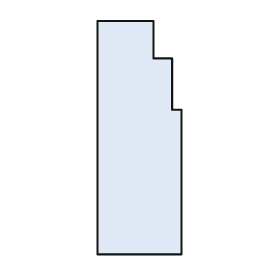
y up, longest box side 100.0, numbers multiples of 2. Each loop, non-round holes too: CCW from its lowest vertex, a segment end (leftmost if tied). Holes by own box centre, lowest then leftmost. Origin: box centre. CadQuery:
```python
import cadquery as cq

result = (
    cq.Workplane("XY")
    .moveTo(-18.0, -50.0)
    .lineTo(18.0, -50.0)
    .lineTo(18.0, 12.0)
    .lineTo(14.0, 12.0)
    .lineTo(14.0, 34.0)
    .lineTo(6.0, 34.0)
    .lineTo(6.0, 50.0)
    .lineTo(-18.0, 50.0)
    .close()
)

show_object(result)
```